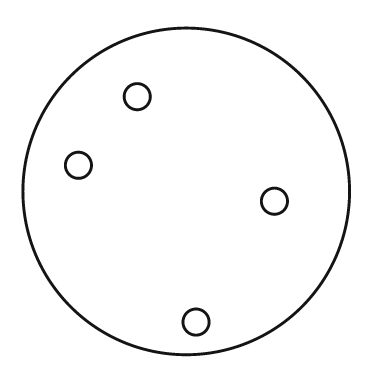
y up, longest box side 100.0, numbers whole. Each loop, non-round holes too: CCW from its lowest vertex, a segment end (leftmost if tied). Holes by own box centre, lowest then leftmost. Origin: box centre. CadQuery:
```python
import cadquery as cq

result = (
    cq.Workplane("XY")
    .moveTo(0.0, 0.0)
    .circle(50.0)
    .moveTo(3.0, -40.0)
    .circle(4.0)
    .moveTo(27.0, -3.0)
    .circle(4.0)
    .moveTo(-33.0, 8.0)
    .circle(4.0)
    .moveTo(-15.0, 29.0)
    .circle(4.0)
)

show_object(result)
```